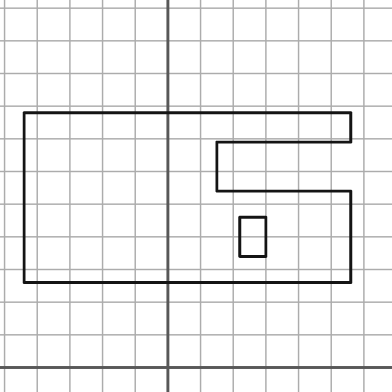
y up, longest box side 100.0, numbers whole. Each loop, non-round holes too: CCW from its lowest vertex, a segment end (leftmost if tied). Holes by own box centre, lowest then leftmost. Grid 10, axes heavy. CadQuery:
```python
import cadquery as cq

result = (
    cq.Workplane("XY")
    .moveTo(-44.0, 26.0)
    .lineTo(56.0, 26.0)
    .lineTo(56.0, 54.0)
    .lineTo(15.0, 54.0)
    .lineTo(15.0, 69.0)
    .lineTo(56.0, 69.0)
    .lineTo(56.0, 78.0)
    .lineTo(-44.0, 78.0)
    .close()
    .moveTo(22.0, 34.0)
    .lineTo(30.0, 34.0)
    .lineTo(30.0, 46.0)
    .lineTo(22.0, 46.0)
    .close()
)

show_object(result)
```